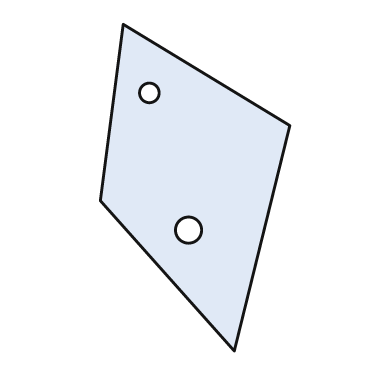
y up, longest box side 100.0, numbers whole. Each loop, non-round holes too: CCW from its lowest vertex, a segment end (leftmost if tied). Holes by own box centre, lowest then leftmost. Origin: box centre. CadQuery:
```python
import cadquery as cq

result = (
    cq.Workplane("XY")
    .moveTo(12.0, -50.0)
    .lineTo(29.0, 19.0)
    .lineTo(-22.0, 50.0)
    .lineTo(-29.0, -4.0)
    .close()
    .moveTo(-2.0, -13.0)
    .circle(4.0)
    .moveTo(-14.0, 29.0)
    .circle(3.0)
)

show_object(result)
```